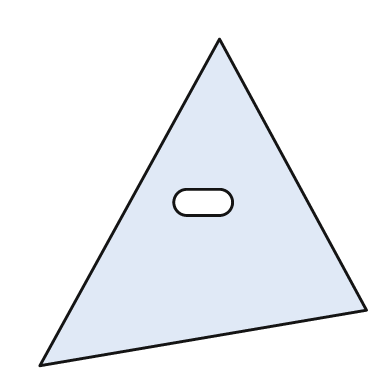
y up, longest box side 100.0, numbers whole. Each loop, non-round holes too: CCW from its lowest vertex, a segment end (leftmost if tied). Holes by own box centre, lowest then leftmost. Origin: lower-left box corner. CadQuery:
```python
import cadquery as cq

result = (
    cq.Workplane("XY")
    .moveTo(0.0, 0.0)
    .lineTo(100.0, 17.0)
    .lineTo(55.0, 100.0)
    .close()
    .moveTo(45.0, 46.0)
    .lineTo(55.0, 46.0)
    .threePointArc((59.0, 50.0), (55.0, 54.0))
    .lineTo(45.0, 54.0)
    .threePointArc((41.0, 50.0), (45.0, 46.0))
    .close()
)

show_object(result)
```